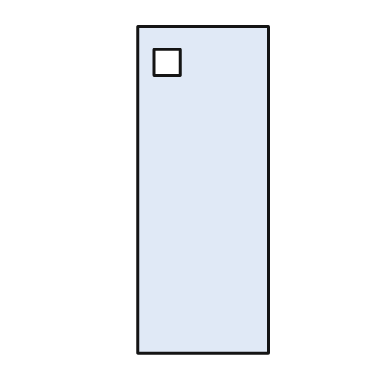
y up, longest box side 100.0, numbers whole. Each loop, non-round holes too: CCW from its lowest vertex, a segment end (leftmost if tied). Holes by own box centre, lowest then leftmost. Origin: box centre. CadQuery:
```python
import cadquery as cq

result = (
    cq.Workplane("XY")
    .moveTo(-20.0, -50.0)
    .lineTo(20.0, -50.0)
    .lineTo(20.0, 50.0)
    .lineTo(-20.0, 50.0)
    .close()
    .moveTo(-15.0, 35.0)
    .lineTo(-7.0, 35.0)
    .lineTo(-7.0, 43.0)
    .lineTo(-15.0, 43.0)
    .close()
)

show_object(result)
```